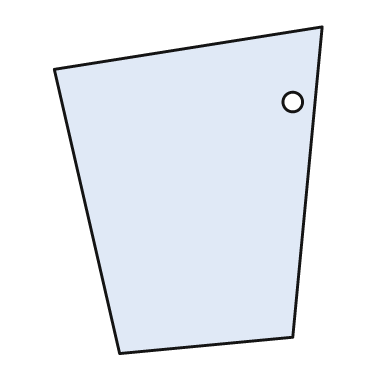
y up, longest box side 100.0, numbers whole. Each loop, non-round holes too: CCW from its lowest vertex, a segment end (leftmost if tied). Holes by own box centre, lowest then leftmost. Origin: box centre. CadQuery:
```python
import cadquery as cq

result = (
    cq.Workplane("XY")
    .moveTo(-21.0, -50.0)
    .lineTo(32.0, -45.0)
    .lineTo(41.0, 50.0)
    .lineTo(-41.0, 37.0)
    .close()
    .moveTo(32.0, 27.0)
    .circle(3.0)
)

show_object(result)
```